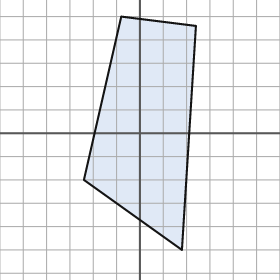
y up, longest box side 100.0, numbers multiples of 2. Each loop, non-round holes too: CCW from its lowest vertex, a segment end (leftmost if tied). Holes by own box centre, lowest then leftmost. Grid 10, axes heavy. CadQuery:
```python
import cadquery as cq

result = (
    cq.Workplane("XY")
    .moveTo(18.0, -50.0)
    .lineTo(24.0, 46.0)
    .lineTo(-8.0, 50.0)
    .lineTo(-24.0, -20.0)
    .close()
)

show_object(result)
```